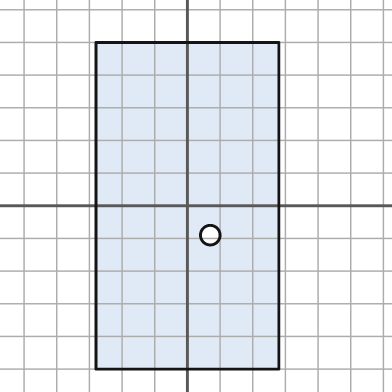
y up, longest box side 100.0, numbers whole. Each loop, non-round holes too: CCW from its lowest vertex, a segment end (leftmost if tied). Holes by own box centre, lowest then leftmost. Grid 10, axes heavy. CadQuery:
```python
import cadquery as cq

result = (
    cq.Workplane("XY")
    .moveTo(-28.0, -50.0)
    .lineTo(28.0, -50.0)
    .lineTo(28.0, 50.0)
    .lineTo(-28.0, 50.0)
    .close()
    .moveTo(7.0, -9.0)
    .circle(3.0)
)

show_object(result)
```